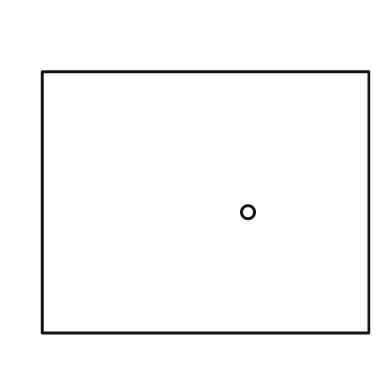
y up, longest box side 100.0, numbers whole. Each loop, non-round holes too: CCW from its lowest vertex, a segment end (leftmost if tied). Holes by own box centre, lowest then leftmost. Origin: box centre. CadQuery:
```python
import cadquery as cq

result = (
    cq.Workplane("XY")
    .moveTo(-50.0, -40.0)
    .lineTo(50.0, -40.0)
    .lineTo(50.0, 40.0)
    .lineTo(-50.0, 40.0)
    .close()
    .moveTo(13.0, -3.0)
    .circle(2.0)
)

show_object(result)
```